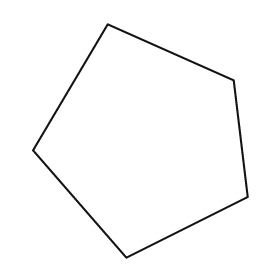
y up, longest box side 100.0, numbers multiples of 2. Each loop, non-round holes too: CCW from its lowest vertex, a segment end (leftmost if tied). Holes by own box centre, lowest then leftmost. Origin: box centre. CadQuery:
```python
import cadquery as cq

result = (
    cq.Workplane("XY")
    .moveTo(-6.0, -50.0)
    .lineTo(46.0, -24.0)
    .lineTo(40.0, 26.0)
    .lineTo(-14.0, 50.0)
    .lineTo(-46.0, -4.0)
    .close()
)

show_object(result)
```